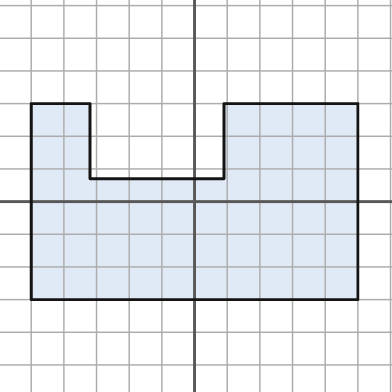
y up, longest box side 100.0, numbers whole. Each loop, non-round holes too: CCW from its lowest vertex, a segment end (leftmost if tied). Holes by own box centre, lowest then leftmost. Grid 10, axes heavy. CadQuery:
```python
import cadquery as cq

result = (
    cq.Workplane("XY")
    .moveTo(-50.0, -30.0)
    .lineTo(50.0, -30.0)
    .lineTo(50.0, 30.0)
    .lineTo(9.0, 30.0)
    .lineTo(9.0, 7.0)
    .lineTo(-32.0, 7.0)
    .lineTo(-32.0, 30.0)
    .lineTo(-50.0, 30.0)
    .close()
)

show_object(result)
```